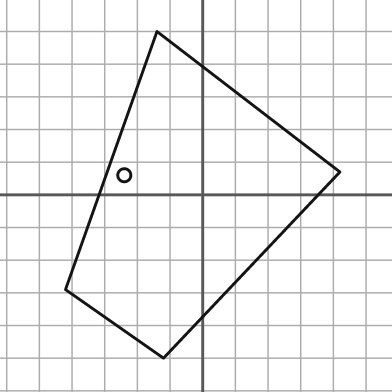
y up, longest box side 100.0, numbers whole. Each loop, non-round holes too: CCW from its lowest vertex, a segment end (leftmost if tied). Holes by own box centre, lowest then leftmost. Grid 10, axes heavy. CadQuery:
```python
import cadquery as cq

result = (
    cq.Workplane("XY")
    .moveTo(-12.0, -50.0)
    .lineTo(42.0, 7.0)
    .lineTo(-14.0, 50.0)
    .lineTo(-42.0, -29.0)
    .close()
    .moveTo(-24.0, 6.0)
    .circle(2.0)
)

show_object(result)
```